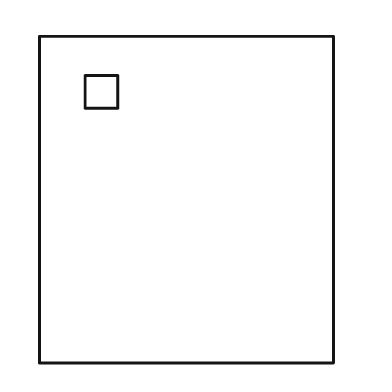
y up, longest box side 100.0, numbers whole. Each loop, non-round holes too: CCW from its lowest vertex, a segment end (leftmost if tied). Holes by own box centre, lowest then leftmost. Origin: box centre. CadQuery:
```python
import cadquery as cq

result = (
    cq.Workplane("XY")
    .moveTo(-45.0, -50.0)
    .lineTo(45.0, -50.0)
    .lineTo(45.0, 50.0)
    .lineTo(-45.0, 50.0)
    .close()
    .moveTo(-31.0, 28.0)
    .lineTo(-21.0, 28.0)
    .lineTo(-21.0, 38.0)
    .lineTo(-31.0, 38.0)
    .close()
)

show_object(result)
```